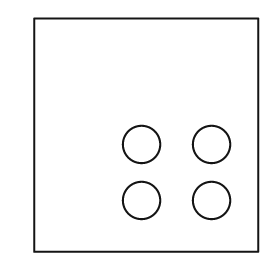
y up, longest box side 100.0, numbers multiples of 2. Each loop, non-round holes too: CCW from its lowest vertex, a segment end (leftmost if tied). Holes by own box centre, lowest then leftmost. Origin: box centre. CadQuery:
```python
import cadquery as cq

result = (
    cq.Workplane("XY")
    .moveTo(-48.0, -50.0)
    .lineTo(48.0, -50.0)
    .lineTo(48.0, 50.0)
    .lineTo(-48.0, 50.0)
    .close()
    .moveTo(-2.0, -28.0)
    .circle(8.0)
    .moveTo(28.0, -28.0)
    .circle(8.0)
    .moveTo(-2.0, -4.0)
    .circle(8.0)
    .moveTo(28.0, -4.0)
    .circle(8.0)
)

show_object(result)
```